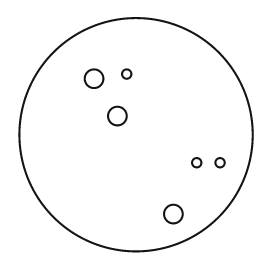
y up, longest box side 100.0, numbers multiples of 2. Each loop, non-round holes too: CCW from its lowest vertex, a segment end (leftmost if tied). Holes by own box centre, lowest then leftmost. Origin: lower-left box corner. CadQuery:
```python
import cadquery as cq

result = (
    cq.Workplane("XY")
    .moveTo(50.0, 50.0)
    .circle(50.0)
    .moveTo(66.0, 16.0)
    .circle(4.0)
    .moveTo(76.0, 38.0)
    .circle(2.0)
    .moveTo(86.0, 38.0)
    .circle(2.0)
    .moveTo(42.0, 58.0)
    .circle(4.0)
    .moveTo(32.0, 74.0)
    .circle(4.0)
    .moveTo(46.0, 76.0)
    .circle(2.0)
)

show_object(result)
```